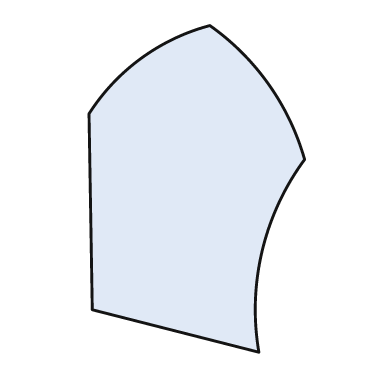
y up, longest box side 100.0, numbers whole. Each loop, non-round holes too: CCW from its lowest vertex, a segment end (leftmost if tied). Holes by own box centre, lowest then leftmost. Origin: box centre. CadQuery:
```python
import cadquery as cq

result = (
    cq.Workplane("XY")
    .moveTo(19.0, -50.0)
    .threePointArc((20.0, -19.0), (33.0, 9.0))
    .threePointArc((22.0, 32.0), (4.0, 50.0))
    .threePointArc((-17.0, 40.0), (-33.0, 23.0))
    .lineTo(-32.0, -37.0)
    .close()
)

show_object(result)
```